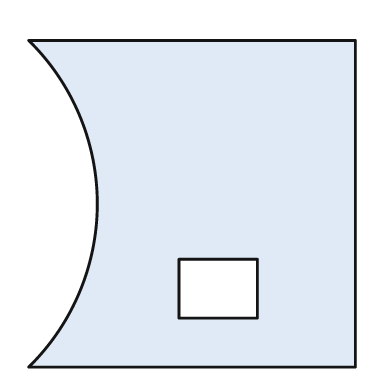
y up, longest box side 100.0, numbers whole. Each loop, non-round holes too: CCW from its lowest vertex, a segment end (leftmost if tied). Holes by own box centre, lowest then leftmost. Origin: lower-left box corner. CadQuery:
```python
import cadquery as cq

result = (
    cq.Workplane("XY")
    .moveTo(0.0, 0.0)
    .lineTo(100.0, 0.0)
    .lineTo(100.0, 100.0)
    .lineTo(0.0, 100.0)
    .threePointArc((21.0, 50.0), (0.0, 0.0))
    .close()
    .moveTo(46.0, 15.0)
    .lineTo(70.0, 15.0)
    .lineTo(70.0, 33.0)
    .lineTo(46.0, 33.0)
    .close()
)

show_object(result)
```